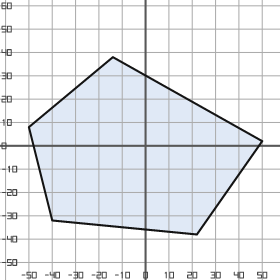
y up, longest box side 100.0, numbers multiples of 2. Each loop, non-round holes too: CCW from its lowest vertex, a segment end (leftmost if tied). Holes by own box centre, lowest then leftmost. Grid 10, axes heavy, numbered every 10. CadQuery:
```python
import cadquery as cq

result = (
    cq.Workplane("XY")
    .moveTo(22.0, -38.0)
    .lineTo(50.0, 2.0)
    .lineTo(-14.0, 38.0)
    .lineTo(-50.0, 8.0)
    .lineTo(-40.0, -32.0)
    .close()
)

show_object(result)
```